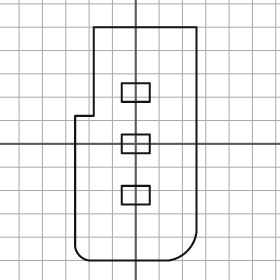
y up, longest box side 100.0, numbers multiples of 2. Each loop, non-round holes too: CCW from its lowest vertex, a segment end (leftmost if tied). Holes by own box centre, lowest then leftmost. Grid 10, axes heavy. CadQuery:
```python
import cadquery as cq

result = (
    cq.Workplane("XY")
    .moveTo(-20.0, -50.0)
    .lineTo(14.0, -50.0)
    .threePointArc((22.0, -46.0), (26.0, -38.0))
    .lineTo(26.0, 50.0)
    .lineTo(-18.0, 50.0)
    .lineTo(-18.0, 12.0)
    .lineTo(-26.0, 12.0)
    .lineTo(-26.0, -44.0)
    .threePointArc((-24.0, -48.0), (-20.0, -50.0))
    .close()
    .moveTo(-6.0, -26.0)
    .lineTo(6.0, -26.0)
    .lineTo(6.0, -18.0)
    .lineTo(-6.0, -18.0)
    .close()
    .moveTo(-6.0, -4.0)
    .lineTo(6.0, -4.0)
    .lineTo(6.0, 4.0)
    .lineTo(-6.0, 4.0)
    .close()
    .moveTo(-6.0, 18.0)
    .lineTo(6.0, 18.0)
    .lineTo(6.0, 26.0)
    .lineTo(-6.0, 26.0)
    .close()
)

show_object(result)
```